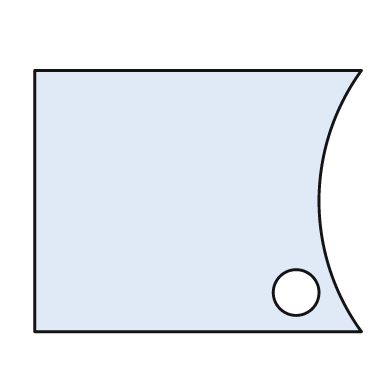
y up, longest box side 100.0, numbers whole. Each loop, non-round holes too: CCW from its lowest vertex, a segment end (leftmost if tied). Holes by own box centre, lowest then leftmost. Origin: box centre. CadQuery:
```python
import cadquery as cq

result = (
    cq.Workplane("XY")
    .moveTo(-50.0, -40.0)
    .lineTo(50.0, -40.0)
    .threePointArc((37.0, 0.0), (50.0, 40.0))
    .lineTo(-50.0, 40.0)
    .close()
    .moveTo(30.0, -28.0)
    .circle(7.0)
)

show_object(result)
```